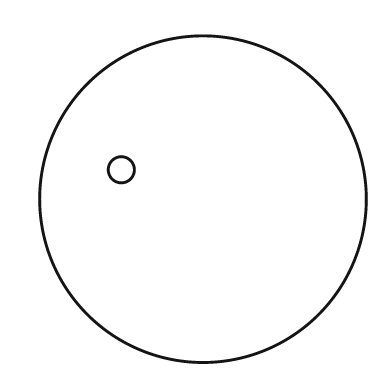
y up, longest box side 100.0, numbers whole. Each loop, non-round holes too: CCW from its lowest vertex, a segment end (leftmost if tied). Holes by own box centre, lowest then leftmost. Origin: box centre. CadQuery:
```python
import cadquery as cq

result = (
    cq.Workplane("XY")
    .moveTo(0.0, 0.0)
    .circle(50.0)
    .moveTo(-25.0, 9.0)
    .circle(4.0)
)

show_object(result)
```